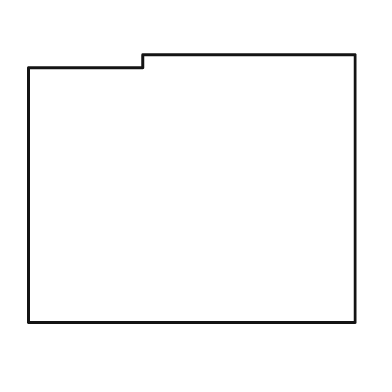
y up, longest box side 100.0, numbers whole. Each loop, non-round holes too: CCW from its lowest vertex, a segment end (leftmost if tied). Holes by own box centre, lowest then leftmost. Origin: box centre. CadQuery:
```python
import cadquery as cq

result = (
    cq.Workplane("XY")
    .moveTo(-50.0, -41.0)
    .lineTo(50.0, -41.0)
    .lineTo(50.0, 41.0)
    .lineTo(-15.0, 41.0)
    .lineTo(-15.0, 37.0)
    .lineTo(-50.0, 37.0)
    .close()
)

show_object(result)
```